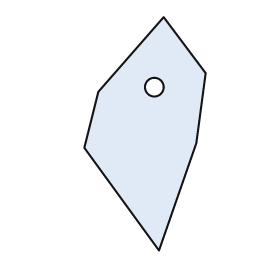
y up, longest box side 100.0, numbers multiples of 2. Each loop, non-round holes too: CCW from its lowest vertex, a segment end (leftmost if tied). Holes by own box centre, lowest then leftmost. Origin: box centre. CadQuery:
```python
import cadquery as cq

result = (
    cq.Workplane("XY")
    .moveTo(6.0, -50.0)
    .lineTo(22.0, -4.0)
    .lineTo(26.0, 26.0)
    .lineTo(8.0, 50.0)
    .lineTo(-20.0, 18.0)
    .lineTo(-26.0, -6.0)
    .close()
    .moveTo(4.0, 20.0)
    .circle(4.0)
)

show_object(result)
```